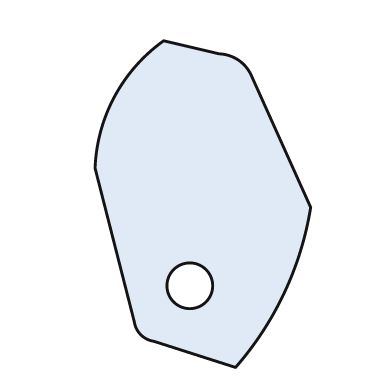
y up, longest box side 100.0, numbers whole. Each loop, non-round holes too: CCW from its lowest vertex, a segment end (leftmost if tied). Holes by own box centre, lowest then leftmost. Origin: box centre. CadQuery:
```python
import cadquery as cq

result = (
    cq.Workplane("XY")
    .moveTo(10.0, -50.0)
    .threePointArc((25.0, -27.0), (33.0, -1.0))
    .lineTo(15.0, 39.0)
    .threePointArc((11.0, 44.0), (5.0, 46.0))
    .lineTo(-12.0, 50.0)
    .threePointArc((-27.0, 33.0), (-33.0, 11.0))
    .lineTo(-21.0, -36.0)
    .threePointArc((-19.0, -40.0), (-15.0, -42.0))
    .close()
    .moveTo(-4.0, -25.0)
    .circle(7.0)
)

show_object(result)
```